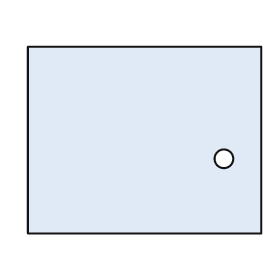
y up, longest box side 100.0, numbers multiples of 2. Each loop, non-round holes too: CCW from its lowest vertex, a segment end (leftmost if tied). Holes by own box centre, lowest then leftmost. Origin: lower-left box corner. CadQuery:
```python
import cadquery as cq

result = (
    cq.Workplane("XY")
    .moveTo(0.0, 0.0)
    .lineTo(100.0, 0.0)
    .lineTo(100.0, 80.0)
    .lineTo(0.0, 80.0)
    .close()
    .moveTo(84.0, 32.0)
    .circle(4.0)
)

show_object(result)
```